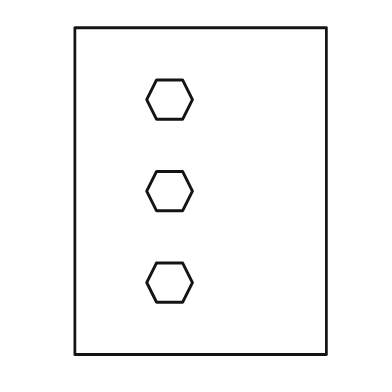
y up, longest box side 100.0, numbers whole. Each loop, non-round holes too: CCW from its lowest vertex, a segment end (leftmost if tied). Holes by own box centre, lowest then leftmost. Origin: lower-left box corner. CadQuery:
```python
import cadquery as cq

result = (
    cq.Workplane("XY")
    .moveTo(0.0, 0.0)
    .lineTo(77.0, 0.0)
    .lineTo(77.0, 100.0)
    .lineTo(0.0, 100.0)
    .close()
    .moveTo(25.0, 16.0)
    .lineTo(33.0, 16.0)
    .lineTo(36.0, 22.0)
    .lineTo(33.0, 28.0)
    .lineTo(25.0, 28.0)
    .lineTo(22.0, 22.0)
    .close()
    .moveTo(25.0, 44.0)
    .lineTo(33.0, 44.0)
    .lineTo(36.0, 50.0)
    .lineTo(33.0, 56.0)
    .lineTo(25.0, 56.0)
    .lineTo(22.0, 50.0)
    .close()
    .moveTo(25.0, 72.0)
    .lineTo(33.0, 72.0)
    .lineTo(36.0, 78.0)
    .lineTo(33.0, 84.0)
    .lineTo(25.0, 84.0)
    .lineTo(22.0, 78.0)
    .close()
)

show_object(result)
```